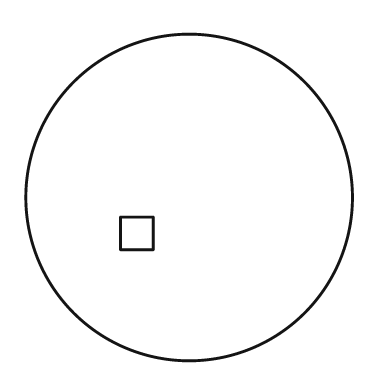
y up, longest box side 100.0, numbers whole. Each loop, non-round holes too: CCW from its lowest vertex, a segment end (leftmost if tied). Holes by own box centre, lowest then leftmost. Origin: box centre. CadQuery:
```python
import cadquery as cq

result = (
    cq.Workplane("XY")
    .moveTo(0.0, 0.0)
    .circle(50.0)
    .moveTo(-21.0, -16.0)
    .lineTo(-11.0, -16.0)
    .lineTo(-11.0, -6.0)
    .lineTo(-21.0, -6.0)
    .close()
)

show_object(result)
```